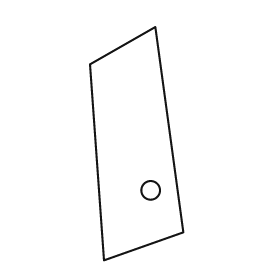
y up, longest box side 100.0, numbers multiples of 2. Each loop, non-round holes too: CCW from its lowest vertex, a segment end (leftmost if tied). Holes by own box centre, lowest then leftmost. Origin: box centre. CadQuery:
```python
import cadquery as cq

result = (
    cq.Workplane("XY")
    .moveTo(-14.0, -50.0)
    .lineTo(20.0, -38.0)
    .lineTo(8.0, 50.0)
    .lineTo(-20.0, 34.0)
    .close()
    .moveTo(6.0, -20.0)
    .circle(4.0)
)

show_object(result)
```